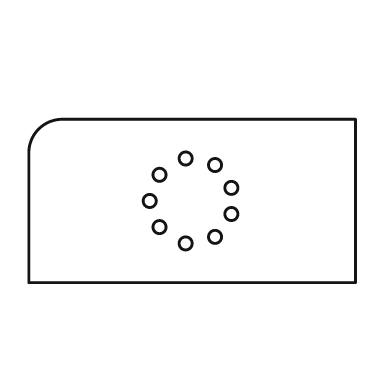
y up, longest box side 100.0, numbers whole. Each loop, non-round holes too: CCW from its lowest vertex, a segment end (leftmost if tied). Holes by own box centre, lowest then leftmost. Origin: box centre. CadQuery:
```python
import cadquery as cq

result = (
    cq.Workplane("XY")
    .moveTo(-50.0, -25.0)
    .lineTo(50.0, -25.0)
    .lineTo(50.0, 25.0)
    .lineTo(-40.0, 25.0)
    .threePointArc((-47.0, 22.0), (-50.0, 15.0))
    .close()
    .moveTo(-2.0, -13.0)
    .circle(2.0)
    .moveTo(7.0, -11.0)
    .circle(2.0)
    .moveTo(-10.0, -8.0)
    .circle(2.0)
    .moveTo(12.0, -4.0)
    .circle(2.0)
    .moveTo(-13.0, 0.0)
    .circle(2.0)
    .moveTo(12.0, 4.0)
    .circle(2.0)
    .moveTo(-10.0, 8.0)
    .circle(2.0)
    .moveTo(7.0, 11.0)
    .circle(2.0)
    .moveTo(-2.0, 13.0)
    .circle(2.0)
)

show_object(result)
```